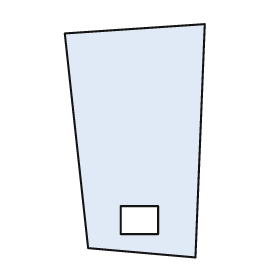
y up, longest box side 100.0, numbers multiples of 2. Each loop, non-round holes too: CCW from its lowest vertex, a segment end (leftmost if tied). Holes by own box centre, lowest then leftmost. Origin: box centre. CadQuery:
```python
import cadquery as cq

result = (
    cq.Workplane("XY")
    .moveTo(26.0, -50.0)
    .lineTo(30.0, 50.0)
    .lineTo(-30.0, 46.0)
    .lineTo(-20.0, -46.0)
    .close()
    .moveTo(-6.0, -40.0)
    .lineTo(10.0, -40.0)
    .lineTo(10.0, -28.0)
    .lineTo(-6.0, -28.0)
    .close()
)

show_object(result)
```